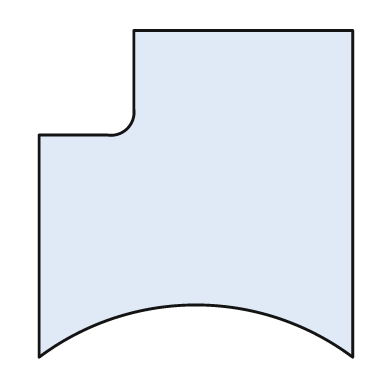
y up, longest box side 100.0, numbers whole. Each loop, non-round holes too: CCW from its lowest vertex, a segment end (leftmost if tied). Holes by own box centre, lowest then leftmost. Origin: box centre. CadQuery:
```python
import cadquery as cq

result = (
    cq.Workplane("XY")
    .moveTo(-48.0, -50.0)
    .threePointArc((0.0, -34.0), (48.0, -50.0))
    .lineTo(48.0, 50.0)
    .lineTo(-19.0, 50.0)
    .lineTo(-19.0, 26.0)
    .threePointArc((-21.0, 20.0), (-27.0, 18.0))
    .lineTo(-48.0, 18.0)
    .close()
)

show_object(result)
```